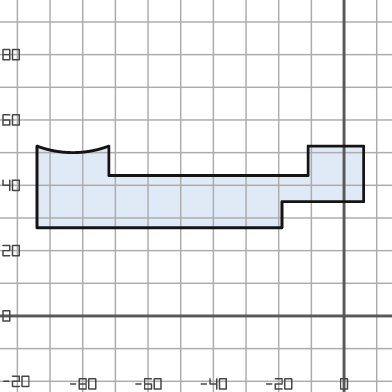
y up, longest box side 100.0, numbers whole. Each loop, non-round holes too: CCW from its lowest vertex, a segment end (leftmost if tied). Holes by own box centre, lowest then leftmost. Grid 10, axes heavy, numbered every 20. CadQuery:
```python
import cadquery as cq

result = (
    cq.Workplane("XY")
    .moveTo(-94.0, 27.0)
    .lineTo(-19.0, 27.0)
    .lineTo(-19.0, 35.0)
    .lineTo(6.0, 35.0)
    .lineTo(6.0, 52.0)
    .lineTo(-11.0, 52.0)
    .lineTo(-11.0, 43.0)
    .lineTo(-72.0, 43.0)
    .lineTo(-72.0, 52.0)
    .threePointArc((-83.0, 50.0), (-94.0, 52.0))
    .close()
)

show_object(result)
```